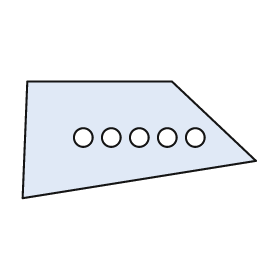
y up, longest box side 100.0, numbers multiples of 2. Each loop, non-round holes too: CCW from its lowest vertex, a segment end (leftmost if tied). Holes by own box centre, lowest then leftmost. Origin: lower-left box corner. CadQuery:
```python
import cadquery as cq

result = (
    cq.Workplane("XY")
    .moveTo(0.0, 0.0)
    .lineTo(100.0, 16.0)
    .lineTo(64.0, 50.0)
    .lineTo(2.0, 50.0)
    .close()
    .moveTo(26.0, 26.0)
    .circle(4.0)
    .moveTo(38.0, 26.0)
    .circle(4.0)
    .moveTo(50.0, 26.0)
    .circle(4.0)
    .moveTo(62.0, 26.0)
    .circle(4.0)
    .moveTo(74.0, 26.0)
    .circle(4.0)
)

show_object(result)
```